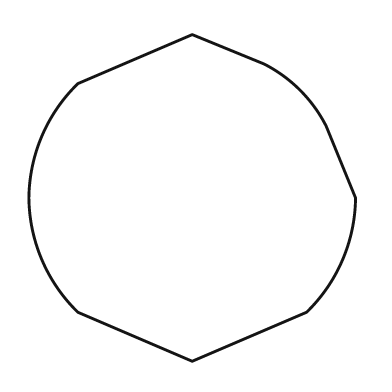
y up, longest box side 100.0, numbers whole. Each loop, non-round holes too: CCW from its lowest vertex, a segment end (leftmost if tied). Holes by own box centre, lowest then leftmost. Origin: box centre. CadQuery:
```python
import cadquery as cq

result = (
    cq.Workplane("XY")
    .moveTo(0.0, -50.0)
    .lineTo(35.0, -35.0)
    .threePointArc((46.0, -19.0), (50.0, 0.0))
    .lineTo(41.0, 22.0)
    .threePointArc((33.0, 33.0), (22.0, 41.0))
    .lineTo(0.0, 50.0)
    .lineTo(-35.0, 35.0)
    .threePointArc((-46.0, 19.0), (-50.0, 0.0))
    .threePointArc((-46.0, -19.0), (-35.0, -35.0))
    .close()
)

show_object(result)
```